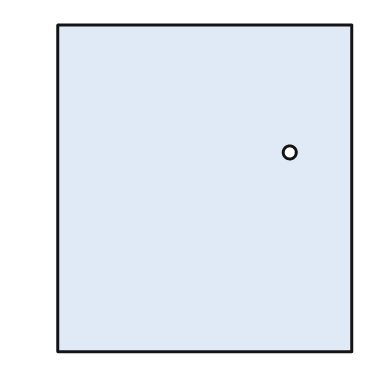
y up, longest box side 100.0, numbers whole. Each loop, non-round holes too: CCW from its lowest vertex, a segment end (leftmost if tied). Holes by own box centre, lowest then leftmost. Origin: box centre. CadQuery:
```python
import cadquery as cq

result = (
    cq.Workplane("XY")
    .moveTo(-45.0, -50.0)
    .lineTo(45.0, -50.0)
    .lineTo(45.0, 50.0)
    .lineTo(-45.0, 50.0)
    .close()
    .moveTo(26.0, 11.0)
    .circle(2.0)
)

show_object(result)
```